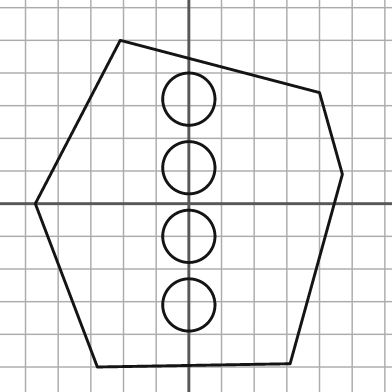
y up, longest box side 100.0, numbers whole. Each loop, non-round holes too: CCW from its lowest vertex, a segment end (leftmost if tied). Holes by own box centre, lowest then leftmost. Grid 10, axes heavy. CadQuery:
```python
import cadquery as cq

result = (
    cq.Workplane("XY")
    .moveTo(-28.0, -50.0)
    .lineTo(31.0, -49.0)
    .lineTo(47.0, 9.0)
    .lineTo(40.0, 34.0)
    .lineTo(-21.0, 50.0)
    .lineTo(-47.0, 0.0)
    .close()
    .moveTo(0.0, -31.0)
    .circle(8.0)
    .moveTo(0.0, -10.0)
    .circle(8.0)
    .moveTo(0.0, 11.0)
    .circle(8.0)
    .moveTo(0.0, 32.0)
    .circle(8.0)
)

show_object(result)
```